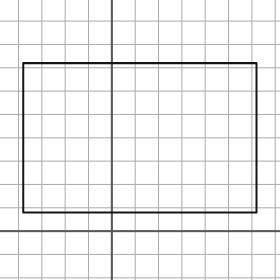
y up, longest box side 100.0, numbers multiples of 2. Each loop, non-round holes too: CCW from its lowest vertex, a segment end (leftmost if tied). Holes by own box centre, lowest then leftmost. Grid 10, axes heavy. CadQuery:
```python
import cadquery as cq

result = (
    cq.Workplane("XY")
    .moveTo(-38.0, 8.0)
    .lineTo(62.0, 8.0)
    .lineTo(62.0, 72.0)
    .lineTo(-38.0, 72.0)
    .close()
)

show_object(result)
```